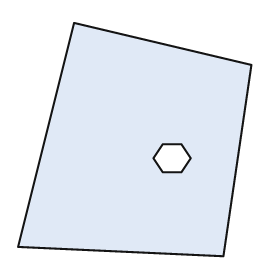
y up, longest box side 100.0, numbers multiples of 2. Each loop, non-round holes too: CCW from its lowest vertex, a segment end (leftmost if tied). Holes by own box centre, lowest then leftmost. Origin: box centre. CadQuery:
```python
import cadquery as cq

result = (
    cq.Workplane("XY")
    .moveTo(38.0, -50.0)
    .lineTo(50.0, 32.0)
    .lineTo(-26.0, 50.0)
    .lineTo(-50.0, -46.0)
    .close()
    .moveTo(12.0, -14.0)
    .lineTo(20.0, -14.0)
    .lineTo(24.0, -8.0)
    .lineTo(20.0, -2.0)
    .lineTo(12.0, -2.0)
    .lineTo(8.0, -8.0)
    .close()
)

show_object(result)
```